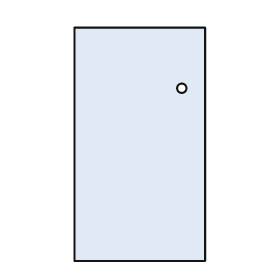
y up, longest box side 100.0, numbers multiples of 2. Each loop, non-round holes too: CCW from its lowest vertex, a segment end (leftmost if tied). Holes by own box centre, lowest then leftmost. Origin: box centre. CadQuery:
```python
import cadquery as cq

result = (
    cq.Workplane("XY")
    .moveTo(-28.0, -50.0)
    .lineTo(28.0, -50.0)
    .lineTo(28.0, 50.0)
    .lineTo(-28.0, 50.0)
    .close()
    .moveTo(18.0, 24.0)
    .circle(2.0)
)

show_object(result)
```